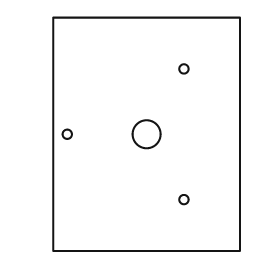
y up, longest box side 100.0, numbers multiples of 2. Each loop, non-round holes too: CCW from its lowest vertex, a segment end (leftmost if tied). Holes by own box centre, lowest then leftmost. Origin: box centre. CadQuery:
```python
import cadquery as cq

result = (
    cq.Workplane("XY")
    .moveTo(-40.0, -50.0)
    .lineTo(40.0, -50.0)
    .lineTo(40.0, 50.0)
    .lineTo(-40.0, 50.0)
    .close()
    .moveTo(16.0, -28.0)
    .circle(2.0)
    .moveTo(-34.0, 0.0)
    .circle(2.0)
    .moveTo(0.0, 0.0)
    .circle(6.0)
    .moveTo(16.0, 28.0)
    .circle(2.0)
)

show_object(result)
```